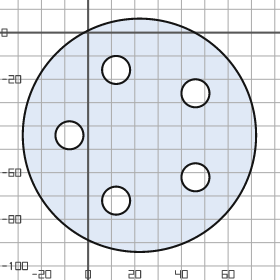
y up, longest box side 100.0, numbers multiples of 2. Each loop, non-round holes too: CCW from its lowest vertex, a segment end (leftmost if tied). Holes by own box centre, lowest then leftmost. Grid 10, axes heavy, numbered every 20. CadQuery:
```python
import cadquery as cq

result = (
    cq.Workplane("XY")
    .moveTo(22.0, -44.0)
    .circle(50.0)
    .moveTo(12.0, -72.0)
    .circle(6.0)
    .moveTo(46.0, -62.0)
    .circle(6.0)
    .moveTo(-8.0, -44.0)
    .circle(6.0)
    .moveTo(46.0, -26.0)
    .circle(6.0)
    .moveTo(12.0, -16.0)
    .circle(6.0)
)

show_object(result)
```